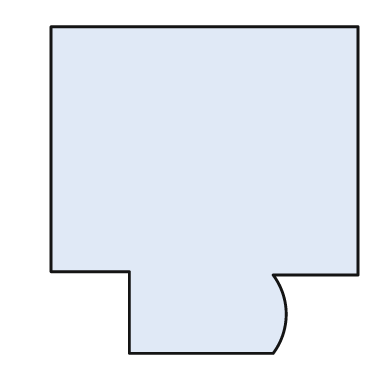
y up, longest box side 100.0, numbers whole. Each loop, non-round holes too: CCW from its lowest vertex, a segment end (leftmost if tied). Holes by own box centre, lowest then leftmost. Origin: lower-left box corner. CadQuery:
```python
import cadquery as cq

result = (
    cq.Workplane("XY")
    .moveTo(24.0, 0.0)
    .lineTo(68.0, 0.0)
    .threePointArc((72.0, 12.0), (68.0, 24.0))
    .lineTo(94.0, 24.0)
    .lineTo(94.0, 100.0)
    .lineTo(0.0, 100.0)
    .lineTo(0.0, 25.0)
    .lineTo(24.0, 25.0)
    .close()
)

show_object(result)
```